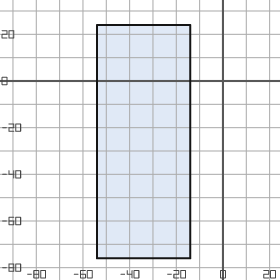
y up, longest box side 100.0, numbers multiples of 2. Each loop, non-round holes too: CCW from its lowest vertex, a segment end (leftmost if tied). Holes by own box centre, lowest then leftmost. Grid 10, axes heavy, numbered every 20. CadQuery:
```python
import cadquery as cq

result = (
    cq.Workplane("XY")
    .moveTo(-54.0, -76.0)
    .lineTo(-14.0, -76.0)
    .lineTo(-14.0, 24.0)
    .lineTo(-54.0, 24.0)
    .close()
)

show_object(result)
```